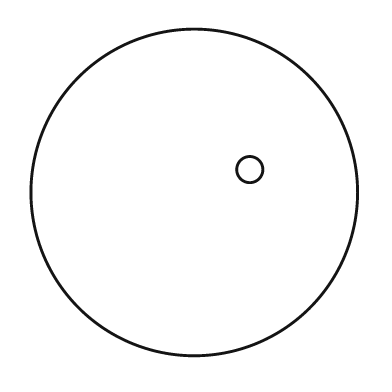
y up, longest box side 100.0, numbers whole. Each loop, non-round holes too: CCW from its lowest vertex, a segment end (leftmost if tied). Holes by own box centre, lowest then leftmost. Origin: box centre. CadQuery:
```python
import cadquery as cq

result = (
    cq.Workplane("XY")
    .moveTo(0.0, 0.0)
    .circle(50.0)
    .moveTo(17.0, 7.0)
    .circle(4.0)
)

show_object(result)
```